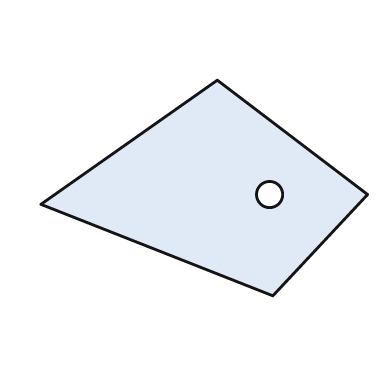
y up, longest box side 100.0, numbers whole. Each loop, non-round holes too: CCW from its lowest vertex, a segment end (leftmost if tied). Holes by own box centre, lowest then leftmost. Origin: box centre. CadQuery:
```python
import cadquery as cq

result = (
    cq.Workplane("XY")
    .moveTo(21.0, -33.0)
    .lineTo(50.0, -2.0)
    .lineTo(4.0, 33.0)
    .lineTo(-50.0, -5.0)
    .close()
    .moveTo(20.0, -2.0)
    .circle(4.0)
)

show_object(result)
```